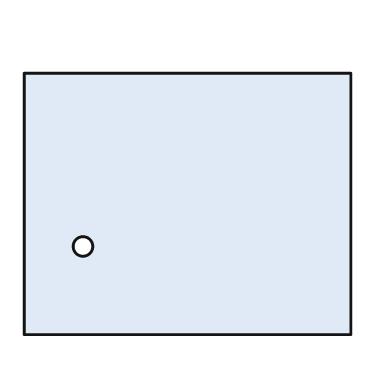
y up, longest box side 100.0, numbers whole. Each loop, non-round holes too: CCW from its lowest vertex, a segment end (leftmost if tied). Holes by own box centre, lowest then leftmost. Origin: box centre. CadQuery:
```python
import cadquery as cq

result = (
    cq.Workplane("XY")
    .moveTo(-50.0, -40.0)
    .lineTo(50.0, -40.0)
    .lineTo(50.0, 40.0)
    .lineTo(-50.0, 40.0)
    .close()
    .moveTo(-32.0, -13.0)
    .circle(3.0)
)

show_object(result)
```